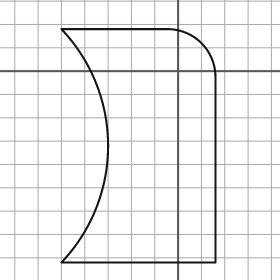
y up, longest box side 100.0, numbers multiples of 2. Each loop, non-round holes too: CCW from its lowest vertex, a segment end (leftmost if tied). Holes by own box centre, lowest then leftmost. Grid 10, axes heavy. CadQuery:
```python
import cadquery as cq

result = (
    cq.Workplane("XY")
    .moveTo(-50.0, -82.0)
    .lineTo(16.0, -82.0)
    .lineTo(16.0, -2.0)
    .threePointArc((10.0, 12.0), (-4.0, 18.0))
    .lineTo(-50.0, 18.0)
    .threePointArc((-30.0, -32.0), (-50.0, -82.0))
    .close()
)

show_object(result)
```